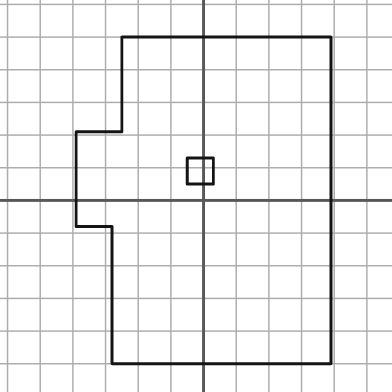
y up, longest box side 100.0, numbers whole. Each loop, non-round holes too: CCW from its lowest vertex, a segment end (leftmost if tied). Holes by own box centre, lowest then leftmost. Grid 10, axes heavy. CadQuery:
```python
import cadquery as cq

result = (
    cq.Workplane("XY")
    .moveTo(-28.0, -50.0)
    .lineTo(39.0, -50.0)
    .lineTo(39.0, 50.0)
    .lineTo(-25.0, 50.0)
    .lineTo(-25.0, 21.0)
    .lineTo(-39.0, 21.0)
    .lineTo(-39.0, -8.0)
    .lineTo(-28.0, -8.0)
    .close()
    .moveTo(-5.0, 5.0)
    .lineTo(3.0, 5.0)
    .lineTo(3.0, 13.0)
    .lineTo(-5.0, 13.0)
    .close()
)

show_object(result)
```